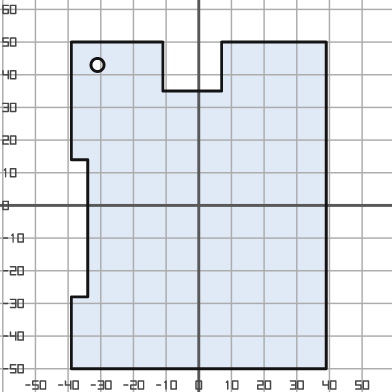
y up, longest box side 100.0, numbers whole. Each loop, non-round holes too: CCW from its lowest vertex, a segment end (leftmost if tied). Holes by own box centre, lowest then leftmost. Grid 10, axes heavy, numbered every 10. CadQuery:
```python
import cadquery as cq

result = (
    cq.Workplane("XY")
    .moveTo(-39.0, -50.0)
    .lineTo(39.0, -50.0)
    .lineTo(39.0, 50.0)
    .lineTo(7.0, 50.0)
    .lineTo(7.0, 35.0)
    .lineTo(-11.0, 35.0)
    .lineTo(-11.0, 50.0)
    .lineTo(-39.0, 50.0)
    .lineTo(-39.0, 14.0)
    .lineTo(-34.0, 14.0)
    .lineTo(-34.0, -28.0)
    .lineTo(-39.0, -28.0)
    .close()
    .moveTo(-31.0, 43.0)
    .circle(2.0)
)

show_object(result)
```